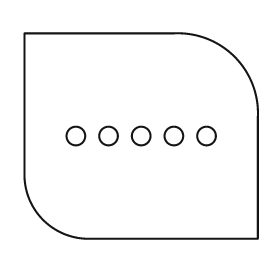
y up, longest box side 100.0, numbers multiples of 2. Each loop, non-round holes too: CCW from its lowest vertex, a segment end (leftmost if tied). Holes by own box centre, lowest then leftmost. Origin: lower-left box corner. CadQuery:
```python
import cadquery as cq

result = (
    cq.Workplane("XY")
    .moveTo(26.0, 0.0)
    .lineTo(100.0, 0.0)
    .lineTo(100.0, 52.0)
    .threePointArc((90.0, 78.0), (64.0, 88.0))
    .lineTo(0.0, 88.0)
    .lineTo(0.0, 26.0)
    .threePointArc((8.0, 8.0), (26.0, 0.0))
    .close()
    .moveTo(22.0, 44.0)
    .circle(4.0)
    .moveTo(36.0, 44.0)
    .circle(4.0)
    .moveTo(50.0, 44.0)
    .circle(4.0)
    .moveTo(64.0, 44.0)
    .circle(4.0)
    .moveTo(78.0, 44.0)
    .circle(4.0)
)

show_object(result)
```